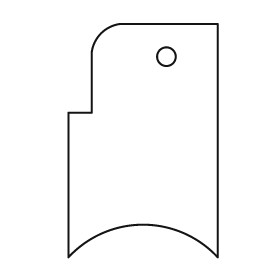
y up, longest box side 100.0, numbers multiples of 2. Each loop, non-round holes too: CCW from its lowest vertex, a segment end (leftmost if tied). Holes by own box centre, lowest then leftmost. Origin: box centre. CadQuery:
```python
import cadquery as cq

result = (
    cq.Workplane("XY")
    .moveTo(-32.0, -50.0)
    .threePointArc((0.0, -36.0), (32.0, -50.0))
    .lineTo(32.0, 50.0)
    .lineTo(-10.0, 50.0)
    .threePointArc((-18.0, 46.0), (-22.0, 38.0))
    .lineTo(-22.0, 12.0)
    .lineTo(-32.0, 12.0)
    .close()
    .moveTo(10.0, 36.0)
    .circle(4.0)
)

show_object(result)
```